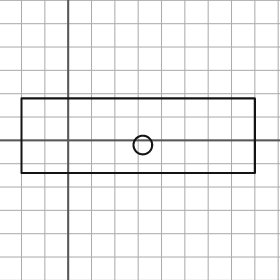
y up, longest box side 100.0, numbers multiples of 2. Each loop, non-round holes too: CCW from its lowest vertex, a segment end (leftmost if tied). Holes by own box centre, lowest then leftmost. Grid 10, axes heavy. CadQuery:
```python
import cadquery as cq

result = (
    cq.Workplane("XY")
    .moveTo(-20.0, -14.0)
    .lineTo(80.0, -14.0)
    .lineTo(80.0, 18.0)
    .lineTo(-20.0, 18.0)
    .close()
    .moveTo(32.0, -2.0)
    .circle(4.0)
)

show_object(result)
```